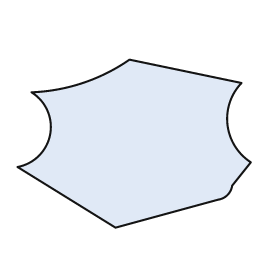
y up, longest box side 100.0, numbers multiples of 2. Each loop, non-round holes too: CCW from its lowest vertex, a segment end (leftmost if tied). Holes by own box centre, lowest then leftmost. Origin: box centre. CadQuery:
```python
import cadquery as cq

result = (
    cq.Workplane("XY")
    .moveTo(-8.0, -36.0)
    .lineTo(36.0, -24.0)
    .threePointArc((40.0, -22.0), (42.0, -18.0))
    .lineTo(50.0, -8.0)
    .threePointArc((40.0, 8.0), (46.0, 26.0))
    .lineTo(-2.0, 36.0)
    .threePointArc((-22.0, 26.0), (-44.0, 22.0))
    .threePointArc((-36.0, 4.0), (-50.0, -10.0))
    .close()
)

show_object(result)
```